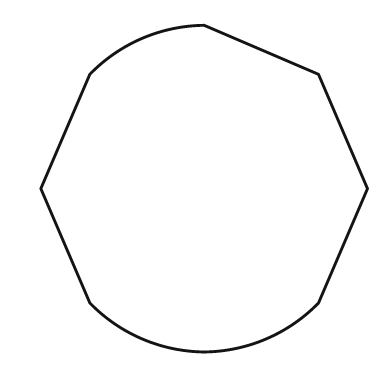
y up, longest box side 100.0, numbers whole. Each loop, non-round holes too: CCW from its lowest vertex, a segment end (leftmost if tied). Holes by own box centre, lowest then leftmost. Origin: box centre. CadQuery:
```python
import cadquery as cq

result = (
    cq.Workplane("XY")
    .moveTo(0.0, -50.0)
    .threePointArc((19.0, -46.0), (35.0, -35.0))
    .lineTo(50.0, 0.0)
    .lineTo(35.0, 35.0)
    .lineTo(0.0, 50.0)
    .threePointArc((-19.0, 46.0), (-35.0, 35.0))
    .lineTo(-50.0, 0.0)
    .lineTo(-35.0, -35.0)
    .threePointArc((-19.0, -46.0), (0.0, -50.0))
    .close()
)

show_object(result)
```